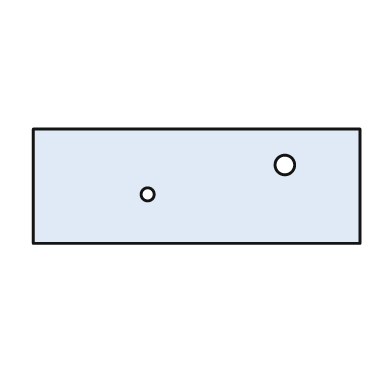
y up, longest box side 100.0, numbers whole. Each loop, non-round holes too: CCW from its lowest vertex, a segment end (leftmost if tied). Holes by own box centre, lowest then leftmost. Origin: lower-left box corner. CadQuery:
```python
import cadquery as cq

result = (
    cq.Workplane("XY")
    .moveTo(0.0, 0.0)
    .lineTo(100.0, 0.0)
    .lineTo(100.0, 35.0)
    .lineTo(0.0, 35.0)
    .close()
    .moveTo(35.0, 15.0)
    .circle(2.0)
    .moveTo(77.0, 24.0)
    .circle(3.0)
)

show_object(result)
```